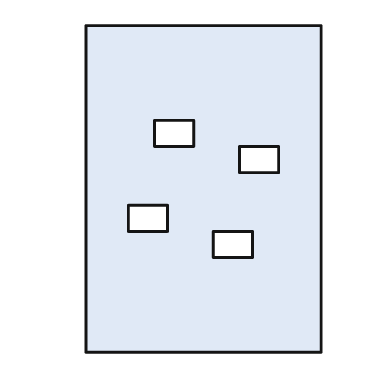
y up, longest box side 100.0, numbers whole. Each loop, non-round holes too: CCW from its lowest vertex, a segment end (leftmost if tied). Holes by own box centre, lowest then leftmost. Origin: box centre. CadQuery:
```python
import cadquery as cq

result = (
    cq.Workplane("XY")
    .moveTo(-36.0, -50.0)
    .lineTo(36.0, -50.0)
    .lineTo(36.0, 50.0)
    .lineTo(-36.0, 50.0)
    .close()
    .moveTo(3.0, -21.0)
    .lineTo(15.0, -21.0)
    .lineTo(15.0, -13.0)
    .lineTo(3.0, -13.0)
    .close()
    .moveTo(-23.0, -13.0)
    .lineTo(-11.0, -13.0)
    .lineTo(-11.0, -5.0)
    .lineTo(-23.0, -5.0)
    .close()
    .moveTo(11.0, 5.0)
    .lineTo(23.0, 5.0)
    .lineTo(23.0, 13.0)
    .lineTo(11.0, 13.0)
    .close()
    .moveTo(-15.0, 13.0)
    .lineTo(-3.0, 13.0)
    .lineTo(-3.0, 21.0)
    .lineTo(-15.0, 21.0)
    .close()
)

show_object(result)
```